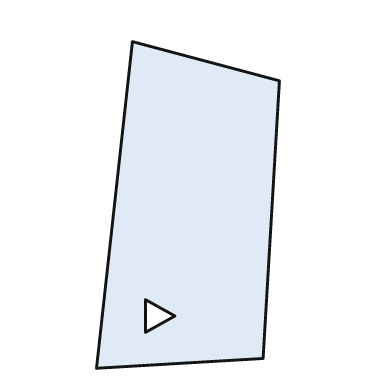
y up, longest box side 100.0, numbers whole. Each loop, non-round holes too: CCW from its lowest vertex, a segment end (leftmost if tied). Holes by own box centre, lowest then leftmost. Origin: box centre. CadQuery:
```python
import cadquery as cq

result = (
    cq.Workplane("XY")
    .moveTo(-28.0, -50.0)
    .lineTo(23.0, -47.0)
    .lineTo(28.0, 38.0)
    .lineTo(-17.0, 50.0)
    .close()
    .moveTo(-13.0, -39.0)
    .lineTo(-4.0, -34.0)
    .lineTo(-13.0, -29.0)
    .close()
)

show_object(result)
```